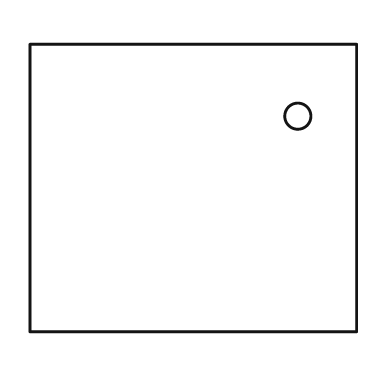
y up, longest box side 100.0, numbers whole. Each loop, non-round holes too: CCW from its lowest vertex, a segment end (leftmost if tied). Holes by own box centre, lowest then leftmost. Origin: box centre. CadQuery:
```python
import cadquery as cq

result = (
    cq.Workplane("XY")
    .moveTo(-50.0, -44.0)
    .lineTo(50.0, -44.0)
    .lineTo(50.0, 44.0)
    .lineTo(-50.0, 44.0)
    .close()
    .moveTo(32.0, 22.0)
    .circle(4.0)
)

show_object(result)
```